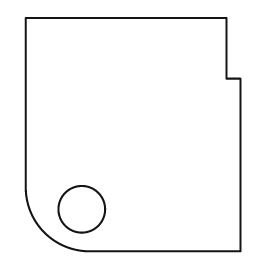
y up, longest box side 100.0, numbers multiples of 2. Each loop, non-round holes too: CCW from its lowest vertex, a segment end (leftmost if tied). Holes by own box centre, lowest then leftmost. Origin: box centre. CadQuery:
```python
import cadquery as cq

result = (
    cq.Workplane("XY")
    .moveTo(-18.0, -50.0)
    .lineTo(46.0, -50.0)
    .lineTo(46.0, 24.0)
    .lineTo(40.0, 24.0)
    .lineTo(40.0, 50.0)
    .lineTo(-46.0, 50.0)
    .lineTo(-46.0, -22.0)
    .threePointArc((-38.0, -42.0), (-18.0, -50.0))
    .close()
    .moveTo(-22.0, -32.0)
    .circle(10.0)
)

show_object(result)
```